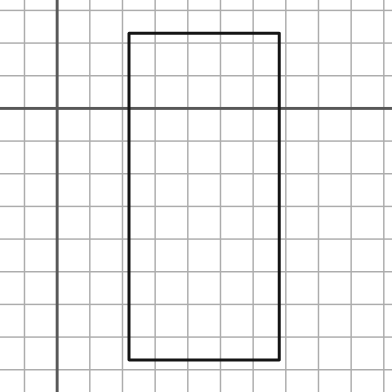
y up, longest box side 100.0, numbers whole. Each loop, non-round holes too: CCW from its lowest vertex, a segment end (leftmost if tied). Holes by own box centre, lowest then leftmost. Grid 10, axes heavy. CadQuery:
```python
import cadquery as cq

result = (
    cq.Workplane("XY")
    .moveTo(22.0, -77.0)
    .lineTo(68.0, -77.0)
    .lineTo(68.0, 23.0)
    .lineTo(22.0, 23.0)
    .close()
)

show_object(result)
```